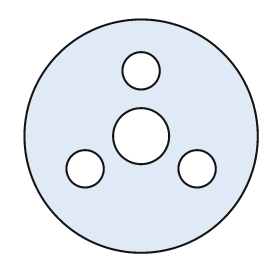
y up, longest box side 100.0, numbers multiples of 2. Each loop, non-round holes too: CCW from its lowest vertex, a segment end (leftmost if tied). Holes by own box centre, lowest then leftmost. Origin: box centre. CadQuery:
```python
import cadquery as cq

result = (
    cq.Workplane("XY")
    .moveTo(0.0, 0.0)
    .circle(50.0)
    .moveTo(-24.0, -14.0)
    .circle(8.0)
    .moveTo(24.0, -14.0)
    .circle(8.0)
    .moveTo(0.0, 0.0)
    .circle(12.0)
    .moveTo(0.0, 28.0)
    .circle(8.0)
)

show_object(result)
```